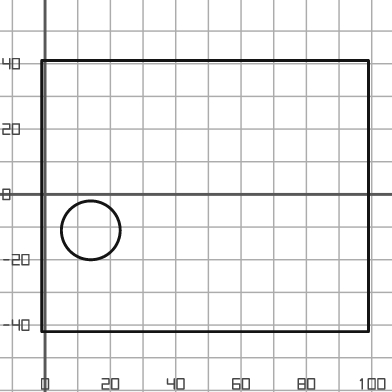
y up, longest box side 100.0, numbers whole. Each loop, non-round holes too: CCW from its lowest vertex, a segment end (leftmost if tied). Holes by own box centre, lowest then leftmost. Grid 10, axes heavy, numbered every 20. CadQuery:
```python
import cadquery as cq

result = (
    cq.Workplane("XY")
    .moveTo(-1.0, -42.0)
    .lineTo(99.0, -42.0)
    .lineTo(99.0, 41.0)
    .lineTo(-1.0, 41.0)
    .close()
    .moveTo(14.0, -11.0)
    .circle(9.0)
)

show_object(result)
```